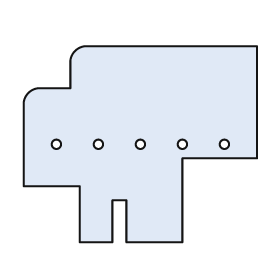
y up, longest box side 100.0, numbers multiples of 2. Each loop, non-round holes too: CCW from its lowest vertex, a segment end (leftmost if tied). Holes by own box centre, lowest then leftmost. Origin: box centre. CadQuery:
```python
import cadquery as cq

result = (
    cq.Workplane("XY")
    .moveTo(-26.0, -42.0)
    .lineTo(-12.0, -42.0)
    .lineTo(-12.0, -24.0)
    .lineTo(-6.0, -24.0)
    .lineTo(-6.0, -42.0)
    .lineTo(18.0, -42.0)
    .lineTo(18.0, -6.0)
    .lineTo(50.0, -6.0)
    .lineTo(50.0, 42.0)
    .lineTo(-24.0, 42.0)
    .threePointArc((-28.0, 40.0), (-30.0, 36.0))
    .lineTo(-30.0, 24.0)
    .lineTo(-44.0, 24.0)
    .threePointArc((-48.0, 22.0), (-50.0, 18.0))
    .lineTo(-50.0, -18.0)
    .lineTo(-26.0, -18.0)
    .close()
    .moveTo(-36.0, 0.0)
    .circle(2.0)
    .moveTo(-18.0, 0.0)
    .circle(2.0)
    .moveTo(0.0, 0.0)
    .circle(2.0)
    .moveTo(18.0, 0.0)
    .circle(2.0)
    .moveTo(36.0, 0.0)
    .circle(2.0)
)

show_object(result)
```